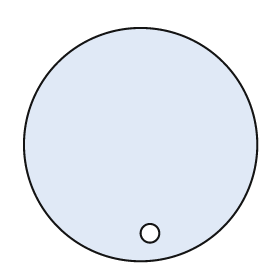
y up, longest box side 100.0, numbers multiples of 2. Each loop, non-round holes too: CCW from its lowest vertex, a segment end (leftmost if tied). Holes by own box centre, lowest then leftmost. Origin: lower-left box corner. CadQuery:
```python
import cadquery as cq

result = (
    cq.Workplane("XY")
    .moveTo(50.0, 50.0)
    .circle(50.0)
    .moveTo(54.0, 12.0)
    .circle(4.0)
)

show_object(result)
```